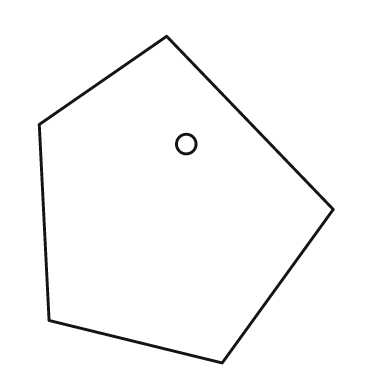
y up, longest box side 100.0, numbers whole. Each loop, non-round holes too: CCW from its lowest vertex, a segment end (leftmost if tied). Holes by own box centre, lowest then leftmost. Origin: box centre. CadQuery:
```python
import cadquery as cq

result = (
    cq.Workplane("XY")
    .moveTo(11.0, -50.0)
    .lineTo(45.0, -3.0)
    .lineTo(-6.0, 50.0)
    .lineTo(-45.0, 23.0)
    .lineTo(-42.0, -37.0)
    .close()
    .moveTo(0.0, 17.0)
    .circle(3.0)
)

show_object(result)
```